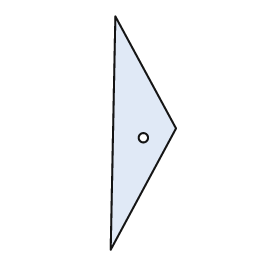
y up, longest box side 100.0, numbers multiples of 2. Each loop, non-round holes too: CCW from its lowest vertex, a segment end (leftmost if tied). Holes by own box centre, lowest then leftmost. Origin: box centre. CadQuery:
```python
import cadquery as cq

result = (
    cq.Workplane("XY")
    .moveTo(-14.0, -50.0)
    .lineTo(14.0, 2.0)
    .lineTo(-12.0, 50.0)
    .close()
    .moveTo(0.0, -2.0)
    .circle(2.0)
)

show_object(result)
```